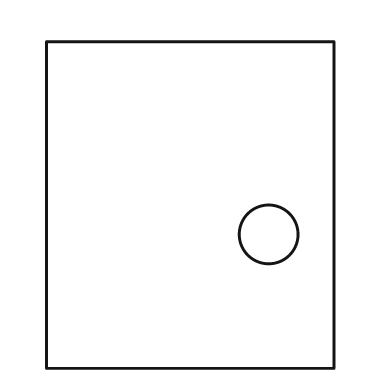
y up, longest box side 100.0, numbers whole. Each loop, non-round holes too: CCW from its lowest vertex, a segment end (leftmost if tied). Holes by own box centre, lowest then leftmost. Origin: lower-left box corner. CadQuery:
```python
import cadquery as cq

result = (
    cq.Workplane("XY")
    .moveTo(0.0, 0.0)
    .lineTo(88.0, 0.0)
    .lineTo(88.0, 100.0)
    .lineTo(0.0, 100.0)
    .close()
    .moveTo(68.0, 41.0)
    .circle(9.0)
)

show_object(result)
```